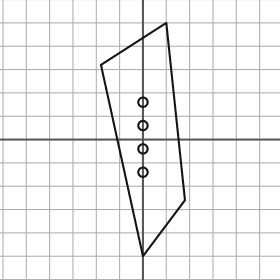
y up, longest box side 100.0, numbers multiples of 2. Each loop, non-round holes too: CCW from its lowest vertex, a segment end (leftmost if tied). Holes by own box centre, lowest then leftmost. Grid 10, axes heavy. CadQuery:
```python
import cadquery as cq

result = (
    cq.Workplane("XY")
    .moveTo(0.0, -50.0)
    .lineTo(18.0, -26.0)
    .lineTo(10.0, 50.0)
    .lineTo(-18.0, 32.0)
    .close()
    .moveTo(0.0, -14.0)
    .circle(2.0)
    .moveTo(0.0, -4.0)
    .circle(2.0)
    .moveTo(0.0, 6.0)
    .circle(2.0)
    .moveTo(0.0, 16.0)
    .circle(2.0)
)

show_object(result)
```